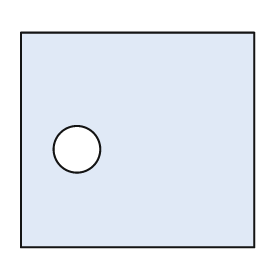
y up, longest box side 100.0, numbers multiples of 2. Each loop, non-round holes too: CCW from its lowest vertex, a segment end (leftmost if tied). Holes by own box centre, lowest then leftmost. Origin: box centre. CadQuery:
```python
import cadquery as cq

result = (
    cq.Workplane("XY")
    .moveTo(-50.0, -46.0)
    .lineTo(50.0, -46.0)
    .lineTo(50.0, 46.0)
    .lineTo(-50.0, 46.0)
    .close()
    .moveTo(-26.0, -4.0)
    .circle(10.0)
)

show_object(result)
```